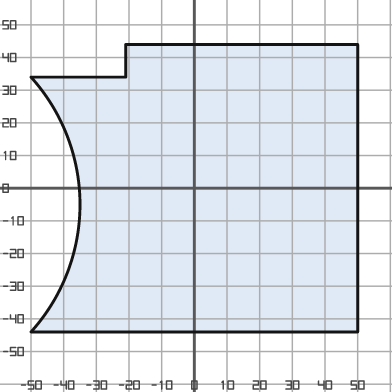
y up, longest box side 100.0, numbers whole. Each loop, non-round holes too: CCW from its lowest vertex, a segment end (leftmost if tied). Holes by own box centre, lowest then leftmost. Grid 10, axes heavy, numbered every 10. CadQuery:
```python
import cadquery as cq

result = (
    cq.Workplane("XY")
    .moveTo(-50.0, -44.0)
    .lineTo(50.0, -44.0)
    .lineTo(50.0, 44.0)
    .lineTo(-21.0, 44.0)
    .lineTo(-21.0, 34.0)
    .lineTo(-50.0, 34.0)
    .threePointArc((-35.0, -5.0), (-50.0, -44.0))
    .close()
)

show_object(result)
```